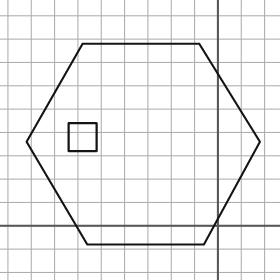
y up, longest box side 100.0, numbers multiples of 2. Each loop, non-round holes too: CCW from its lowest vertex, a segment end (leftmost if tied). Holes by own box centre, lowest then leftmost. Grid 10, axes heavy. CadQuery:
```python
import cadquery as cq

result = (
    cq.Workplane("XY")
    .moveTo(-56.0, -8.0)
    .lineTo(-6.0, -8.0)
    .lineTo(18.0, 36.0)
    .lineTo(-8.0, 78.0)
    .lineTo(-58.0, 78.0)
    .lineTo(-82.0, 36.0)
    .close()
    .moveTo(-64.0, 32.0)
    .lineTo(-52.0, 32.0)
    .lineTo(-52.0, 44.0)
    .lineTo(-64.0, 44.0)
    .close()
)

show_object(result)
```